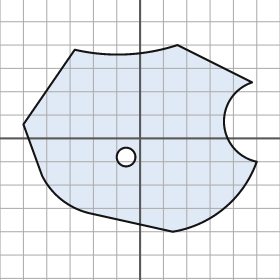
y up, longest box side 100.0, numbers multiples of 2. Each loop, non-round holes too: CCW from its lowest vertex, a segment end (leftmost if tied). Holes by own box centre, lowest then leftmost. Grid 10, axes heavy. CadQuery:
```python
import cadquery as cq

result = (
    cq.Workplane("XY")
    .moveTo(14.0, -40.0)
    .threePointArc((36.0, -30.0), (50.0, -10.0))
    .threePointArc((36.0, 6.0), (48.0, 24.0))
    .lineTo(16.0, 40.0)
    .threePointArc((-6.0, 36.0), (-28.0, 38.0))
    .lineTo(-50.0, 6.0)
    .lineTo(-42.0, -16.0)
    .threePointArc((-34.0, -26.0), (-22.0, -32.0))
    .close()
    .moveTo(-6.0, -8.0)
    .circle(4.0)
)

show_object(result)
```